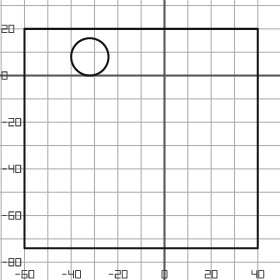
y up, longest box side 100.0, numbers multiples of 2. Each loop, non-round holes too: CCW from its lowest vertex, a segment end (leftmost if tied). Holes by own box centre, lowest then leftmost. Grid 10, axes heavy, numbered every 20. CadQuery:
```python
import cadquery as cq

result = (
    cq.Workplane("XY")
    .moveTo(-60.0, -74.0)
    .lineTo(40.0, -74.0)
    .lineTo(40.0, 20.0)
    .lineTo(-60.0, 20.0)
    .close()
    .moveTo(-32.0, 8.0)
    .circle(8.0)
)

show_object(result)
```